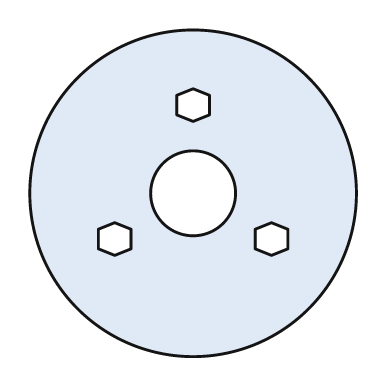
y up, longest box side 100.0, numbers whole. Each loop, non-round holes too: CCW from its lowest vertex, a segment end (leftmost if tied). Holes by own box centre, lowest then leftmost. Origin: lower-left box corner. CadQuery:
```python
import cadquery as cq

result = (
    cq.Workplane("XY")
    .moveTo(50.0, 50.0)
    .circle(50.0)
    .moveTo(26.0, 31.0)
    .lineTo(31.0, 33.0)
    .lineTo(31.0, 39.0)
    .lineTo(26.0, 41.0)
    .lineTo(21.0, 39.0)
    .lineTo(21.0, 33.0)
    .close()
    .moveTo(74.0, 31.0)
    .lineTo(79.0, 33.0)
    .lineTo(79.0, 39.0)
    .lineTo(74.0, 41.0)
    .lineTo(69.0, 39.0)
    .lineTo(69.0, 33.0)
    .close()
    .moveTo(50.0, 50.0)
    .circle(13.0)
    .moveTo(50.0, 72.0)
    .lineTo(55.0, 74.0)
    .lineTo(55.0, 80.0)
    .lineTo(50.0, 82.0)
    .lineTo(45.0, 80.0)
    .lineTo(45.0, 74.0)
    .close()
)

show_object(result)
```